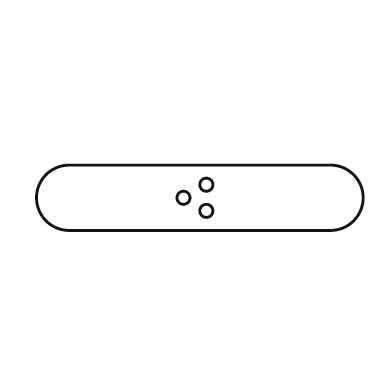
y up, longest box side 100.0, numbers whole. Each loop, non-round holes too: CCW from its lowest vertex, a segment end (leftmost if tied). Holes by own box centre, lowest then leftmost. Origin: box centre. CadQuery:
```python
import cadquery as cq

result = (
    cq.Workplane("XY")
    .moveTo(-40.0, -10.0)
    .lineTo(40.0, -10.0)
    .threePointArc((50.0, 0.0), (40.0, 10.0))
    .lineTo(-40.0, 10.0)
    .threePointArc((-50.0, 0.0), (-40.0, -10.0))
    .close()
    .moveTo(2.0, -4.0)
    .circle(2.0)
    .moveTo(-5.0, 0.0)
    .circle(2.0)
    .moveTo(2.0, 4.0)
    .circle(2.0)
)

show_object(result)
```